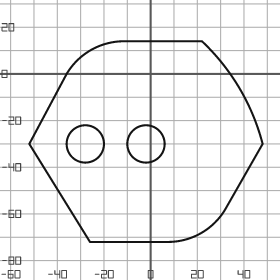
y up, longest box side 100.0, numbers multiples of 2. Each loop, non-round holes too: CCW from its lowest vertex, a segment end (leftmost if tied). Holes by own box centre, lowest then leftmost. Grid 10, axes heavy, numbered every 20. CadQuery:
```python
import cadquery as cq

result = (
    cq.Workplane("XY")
    .moveTo(-26.0, -72.0)
    .lineTo(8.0, -72.0)
    .threePointArc((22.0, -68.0), (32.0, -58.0))
    .lineTo(48.0, -30.0)
    .threePointArc((38.0, -6.0), (22.0, 14.0))
    .lineTo(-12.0, 14.0)
    .threePointArc((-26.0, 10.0), (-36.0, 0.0))
    .lineTo(-52.0, -30.0)
    .close()
    .moveTo(-28.0, -30.0)
    .circle(8.0)
    .moveTo(-2.0, -30.0)
    .circle(8.0)
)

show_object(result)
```